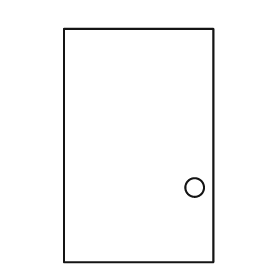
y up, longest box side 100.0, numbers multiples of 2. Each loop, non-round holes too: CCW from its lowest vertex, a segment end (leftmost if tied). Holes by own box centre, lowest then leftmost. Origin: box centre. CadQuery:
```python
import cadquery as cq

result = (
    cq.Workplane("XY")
    .moveTo(-32.0, -50.0)
    .lineTo(32.0, -50.0)
    .lineTo(32.0, 50.0)
    .lineTo(-32.0, 50.0)
    .close()
    .moveTo(24.0, -18.0)
    .circle(4.0)
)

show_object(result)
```